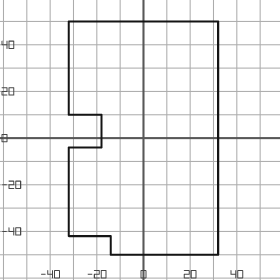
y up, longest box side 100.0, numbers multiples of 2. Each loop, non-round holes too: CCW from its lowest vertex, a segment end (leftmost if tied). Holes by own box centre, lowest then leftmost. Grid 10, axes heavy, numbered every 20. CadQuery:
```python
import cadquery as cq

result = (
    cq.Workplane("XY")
    .moveTo(-14.0, -50.0)
    .lineTo(32.0, -50.0)
    .lineTo(32.0, 50.0)
    .lineTo(-32.0, 50.0)
    .lineTo(-32.0, 10.0)
    .lineTo(-18.0, 10.0)
    .lineTo(-18.0, -4.0)
    .lineTo(-32.0, -4.0)
    .lineTo(-32.0, -42.0)
    .lineTo(-14.0, -42.0)
    .close()
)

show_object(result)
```